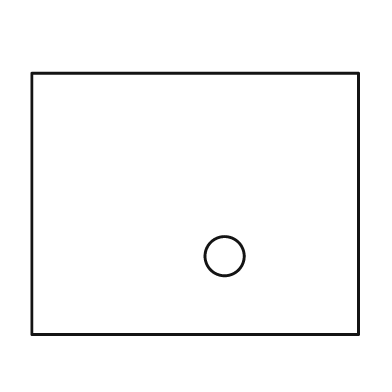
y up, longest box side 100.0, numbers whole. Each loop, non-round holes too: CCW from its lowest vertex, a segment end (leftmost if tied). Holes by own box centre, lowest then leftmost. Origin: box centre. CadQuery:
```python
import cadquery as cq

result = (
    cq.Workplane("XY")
    .moveTo(-50.0, -40.0)
    .lineTo(50.0, -40.0)
    .lineTo(50.0, 40.0)
    .lineTo(-50.0, 40.0)
    .close()
    .moveTo(9.0, -16.0)
    .circle(6.0)
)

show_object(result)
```